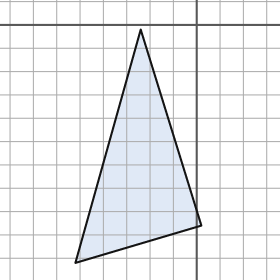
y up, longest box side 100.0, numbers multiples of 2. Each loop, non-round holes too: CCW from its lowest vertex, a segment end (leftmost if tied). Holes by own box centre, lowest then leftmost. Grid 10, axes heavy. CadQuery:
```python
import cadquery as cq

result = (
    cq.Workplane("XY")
    .moveTo(-52.0, -102.0)
    .lineTo(2.0, -86.0)
    .lineTo(-24.0, -2.0)
    .close()
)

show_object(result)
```